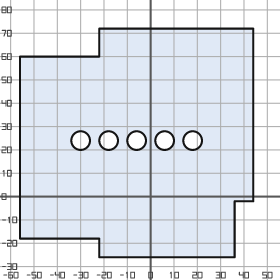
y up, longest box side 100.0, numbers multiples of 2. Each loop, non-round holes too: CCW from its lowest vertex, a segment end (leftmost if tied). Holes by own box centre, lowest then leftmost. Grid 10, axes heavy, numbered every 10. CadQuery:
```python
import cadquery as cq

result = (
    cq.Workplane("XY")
    .moveTo(-22.0, -26.0)
    .lineTo(36.0, -26.0)
    .lineTo(36.0, -2.0)
    .lineTo(44.0, -2.0)
    .lineTo(44.0, 72.0)
    .lineTo(-22.0, 72.0)
    .lineTo(-22.0, 60.0)
    .lineTo(-56.0, 60.0)
    .lineTo(-56.0, -18.0)
    .lineTo(-22.0, -18.0)
    .close()
    .moveTo(-30.0, 24.0)
    .circle(4.0)
    .moveTo(-18.0, 24.0)
    .circle(4.0)
    .moveTo(-6.0, 24.0)
    .circle(4.0)
    .moveTo(6.0, 24.0)
    .circle(4.0)
    .moveTo(18.0, 24.0)
    .circle(4.0)
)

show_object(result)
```